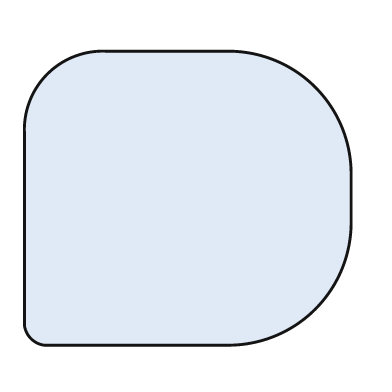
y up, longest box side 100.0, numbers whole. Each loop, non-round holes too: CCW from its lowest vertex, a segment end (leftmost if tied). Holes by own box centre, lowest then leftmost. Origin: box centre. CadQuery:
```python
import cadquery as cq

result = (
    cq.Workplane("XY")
    .moveTo(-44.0, -45.0)
    .lineTo(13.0, -45.0)
    .threePointArc((39.0, -34.0), (50.0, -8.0))
    .lineTo(50.0, 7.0)
    .threePointArc((39.0, 34.0), (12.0, 45.0))
    .lineTo(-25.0, 45.0)
    .threePointArc((-43.0, 38.0), (-50.0, 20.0))
    .lineTo(-50.0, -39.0)
    .threePointArc((-48.0, -43.0), (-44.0, -45.0))
    .close()
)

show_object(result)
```